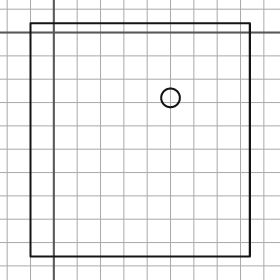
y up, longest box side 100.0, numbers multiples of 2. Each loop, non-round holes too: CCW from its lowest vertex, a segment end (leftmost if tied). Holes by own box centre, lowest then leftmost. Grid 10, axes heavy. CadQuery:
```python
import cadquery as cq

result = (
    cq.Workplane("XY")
    .moveTo(-10.0, -96.0)
    .lineTo(84.0, -96.0)
    .lineTo(84.0, 4.0)
    .lineTo(-10.0, 4.0)
    .close()
    .moveTo(50.0, -28.0)
    .circle(4.0)
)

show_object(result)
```